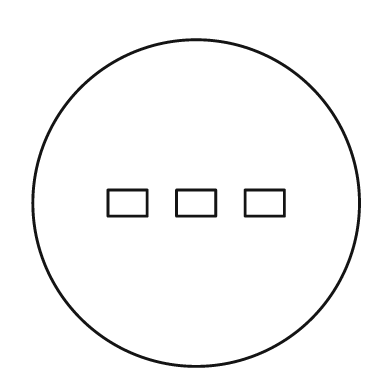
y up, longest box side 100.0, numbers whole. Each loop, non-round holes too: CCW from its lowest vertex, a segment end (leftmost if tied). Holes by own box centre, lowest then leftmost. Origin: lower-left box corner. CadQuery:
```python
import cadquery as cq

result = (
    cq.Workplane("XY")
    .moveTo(50.0, 50.0)
    .circle(50.0)
    .moveTo(23.0, 46.0)
    .lineTo(35.0, 46.0)
    .lineTo(35.0, 54.0)
    .lineTo(23.0, 54.0)
    .close()
    .moveTo(44.0, 46.0)
    .lineTo(56.0, 46.0)
    .lineTo(56.0, 54.0)
    .lineTo(44.0, 54.0)
    .close()
    .moveTo(65.0, 46.0)
    .lineTo(77.0, 46.0)
    .lineTo(77.0, 54.0)
    .lineTo(65.0, 54.0)
    .close()
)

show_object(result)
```